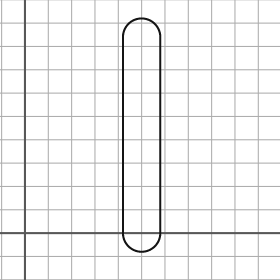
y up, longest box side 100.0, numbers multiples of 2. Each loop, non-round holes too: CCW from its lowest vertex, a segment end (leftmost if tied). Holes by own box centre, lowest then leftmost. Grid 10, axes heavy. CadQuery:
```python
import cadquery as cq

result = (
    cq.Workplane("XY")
    .moveTo(42.0, 0.0)
    .threePointArc((50.0, -8.0), (58.0, 0.0))
    .lineTo(58.0, 84.0)
    .threePointArc((50.0, 92.0), (42.0, 84.0))
    .close()
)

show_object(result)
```